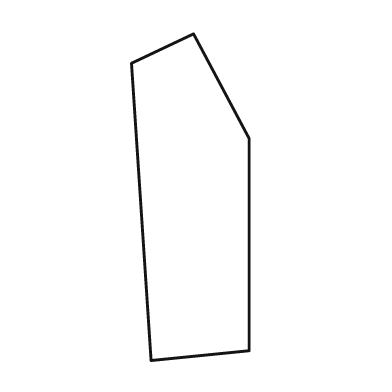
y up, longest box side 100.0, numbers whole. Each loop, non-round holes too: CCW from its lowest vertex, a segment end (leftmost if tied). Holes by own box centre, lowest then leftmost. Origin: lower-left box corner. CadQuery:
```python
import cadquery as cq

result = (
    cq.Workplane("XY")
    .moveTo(6.0, 0.0)
    .lineTo(36.0, 3.0)
    .lineTo(36.0, 68.0)
    .lineTo(19.0, 100.0)
    .lineTo(0.0, 91.0)
    .close()
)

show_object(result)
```